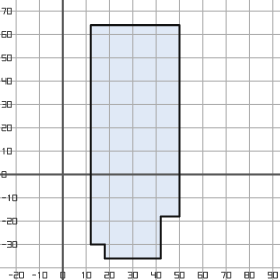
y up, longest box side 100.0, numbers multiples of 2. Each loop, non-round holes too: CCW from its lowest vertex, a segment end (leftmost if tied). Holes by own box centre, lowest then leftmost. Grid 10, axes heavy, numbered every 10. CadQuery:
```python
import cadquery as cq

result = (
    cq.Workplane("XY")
    .moveTo(18.0, -36.0)
    .lineTo(42.0, -36.0)
    .lineTo(42.0, -18.0)
    .lineTo(50.0, -18.0)
    .lineTo(50.0, 64.0)
    .lineTo(12.0, 64.0)
    .lineTo(12.0, -30.0)
    .lineTo(18.0, -30.0)
    .close()
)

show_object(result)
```